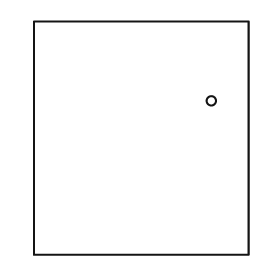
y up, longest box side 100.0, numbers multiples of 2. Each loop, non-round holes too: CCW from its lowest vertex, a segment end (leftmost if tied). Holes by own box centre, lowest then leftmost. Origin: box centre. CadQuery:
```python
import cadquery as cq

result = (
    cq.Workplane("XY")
    .moveTo(-46.0, -50.0)
    .lineTo(46.0, -50.0)
    .lineTo(46.0, 50.0)
    .lineTo(-46.0, 50.0)
    .close()
    .moveTo(30.0, 16.0)
    .circle(2.0)
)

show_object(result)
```